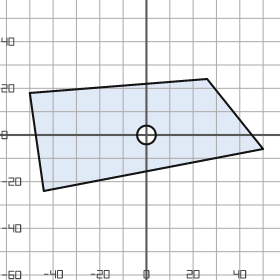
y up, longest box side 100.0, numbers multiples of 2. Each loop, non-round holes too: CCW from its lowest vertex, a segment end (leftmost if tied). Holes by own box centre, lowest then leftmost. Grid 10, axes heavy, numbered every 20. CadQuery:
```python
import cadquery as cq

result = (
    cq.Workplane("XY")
    .moveTo(-44.0, -24.0)
    .lineTo(50.0, -6.0)
    .lineTo(26.0, 24.0)
    .lineTo(-50.0, 18.0)
    .close()
    .moveTo(0.0, 0.0)
    .circle(4.0)
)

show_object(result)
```